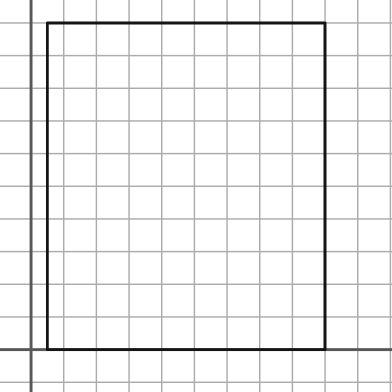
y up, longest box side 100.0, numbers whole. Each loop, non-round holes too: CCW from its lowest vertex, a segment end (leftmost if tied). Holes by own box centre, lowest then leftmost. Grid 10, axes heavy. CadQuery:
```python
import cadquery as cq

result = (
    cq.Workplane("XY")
    .moveTo(5.0, 0.0)
    .lineTo(90.0, 0.0)
    .lineTo(90.0, 100.0)
    .lineTo(5.0, 100.0)
    .close()
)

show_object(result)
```